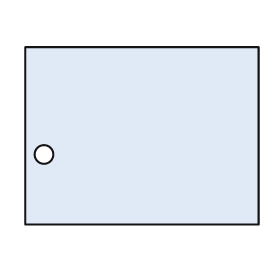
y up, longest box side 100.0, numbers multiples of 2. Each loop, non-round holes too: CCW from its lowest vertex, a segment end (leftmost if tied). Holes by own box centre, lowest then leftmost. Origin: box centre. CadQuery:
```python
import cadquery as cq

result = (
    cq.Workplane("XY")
    .moveTo(-50.0, -38.0)
    .lineTo(50.0, -38.0)
    .lineTo(50.0, 38.0)
    .lineTo(-50.0, 38.0)
    .close()
    .moveTo(-42.0, -8.0)
    .circle(4.0)
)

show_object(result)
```